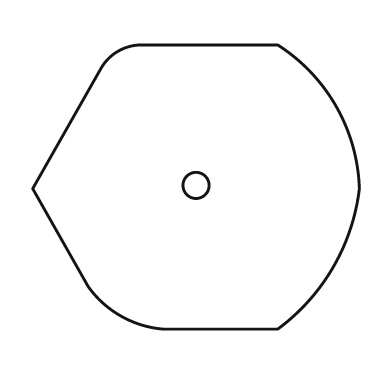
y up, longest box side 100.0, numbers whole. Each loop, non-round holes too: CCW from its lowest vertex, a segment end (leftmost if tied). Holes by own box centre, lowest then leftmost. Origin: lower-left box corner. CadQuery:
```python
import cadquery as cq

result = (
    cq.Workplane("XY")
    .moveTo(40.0, 0.0)
    .lineTo(75.0, 0.0)
    .threePointArc((92.0, 19.0), (100.0, 43.0))
    .threePointArc((93.0, 68.0), (75.0, 87.0))
    .lineTo(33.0, 87.0)
    .threePointArc((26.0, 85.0), (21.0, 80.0))
    .lineTo(0.0, 43.0)
    .lineTo(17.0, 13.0)
    .threePointArc((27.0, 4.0), (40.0, 0.0))
    .close()
    .moveTo(50.0, 44.0)
    .circle(4.0)
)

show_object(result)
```